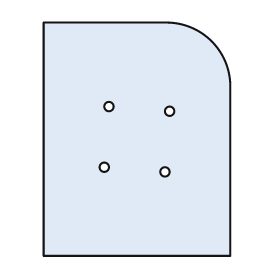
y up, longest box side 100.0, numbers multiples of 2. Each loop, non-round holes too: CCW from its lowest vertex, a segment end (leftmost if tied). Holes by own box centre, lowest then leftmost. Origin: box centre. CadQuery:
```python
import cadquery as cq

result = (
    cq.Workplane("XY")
    .moveTo(-40.0, -50.0)
    .lineTo(40.0, -50.0)
    .lineTo(40.0, 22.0)
    .threePointArc((32.0, 42.0), (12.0, 50.0))
    .lineTo(-40.0, 50.0)
    .close()
    .moveTo(12.0, -14.0)
    .circle(2.0)
    .moveTo(-14.0, -12.0)
    .circle(2.0)
    .moveTo(14.0, 12.0)
    .circle(2.0)
    .moveTo(-12.0, 14.0)
    .circle(2.0)
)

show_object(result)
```